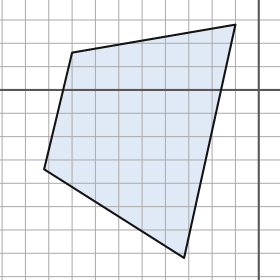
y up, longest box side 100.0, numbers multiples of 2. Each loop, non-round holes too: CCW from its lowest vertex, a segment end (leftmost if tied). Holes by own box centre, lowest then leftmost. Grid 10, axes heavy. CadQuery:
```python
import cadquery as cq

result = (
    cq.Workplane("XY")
    .moveTo(-32.0, -72.0)
    .lineTo(-10.0, 28.0)
    .lineTo(-80.0, 16.0)
    .lineTo(-92.0, -34.0)
    .close()
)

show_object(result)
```